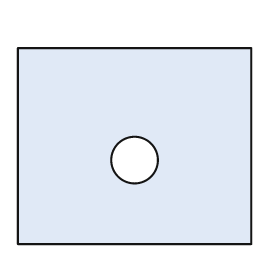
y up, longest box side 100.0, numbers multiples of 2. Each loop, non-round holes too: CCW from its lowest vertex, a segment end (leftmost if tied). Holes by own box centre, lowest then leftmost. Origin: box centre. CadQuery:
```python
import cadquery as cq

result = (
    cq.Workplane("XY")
    .moveTo(-50.0, -42.0)
    .lineTo(50.0, -42.0)
    .lineTo(50.0, 42.0)
    .lineTo(-50.0, 42.0)
    .close()
    .moveTo(0.0, -6.0)
    .circle(10.0)
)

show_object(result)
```